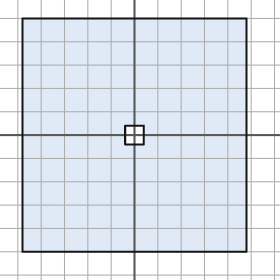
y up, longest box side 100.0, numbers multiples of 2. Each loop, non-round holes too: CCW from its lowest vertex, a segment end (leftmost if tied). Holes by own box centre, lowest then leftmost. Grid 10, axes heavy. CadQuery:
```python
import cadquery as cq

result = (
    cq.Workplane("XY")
    .moveTo(-48.0, -50.0)
    .lineTo(48.0, -50.0)
    .lineTo(48.0, 50.0)
    .lineTo(-48.0, 50.0)
    .close()
    .moveTo(-4.0, -4.0)
    .lineTo(4.0, -4.0)
    .lineTo(4.0, 4.0)
    .lineTo(-4.0, 4.0)
    .close()
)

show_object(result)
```